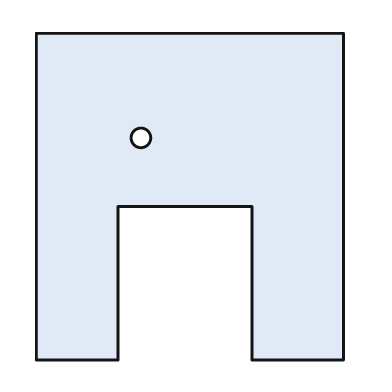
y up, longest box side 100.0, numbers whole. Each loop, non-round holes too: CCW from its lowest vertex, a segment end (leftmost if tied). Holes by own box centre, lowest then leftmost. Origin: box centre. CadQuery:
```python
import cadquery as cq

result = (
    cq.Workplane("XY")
    .moveTo(-47.0, -50.0)
    .lineTo(-22.0, -50.0)
    .lineTo(-22.0, -3.0)
    .lineTo(19.0, -3.0)
    .lineTo(19.0, -50.0)
    .lineTo(47.0, -50.0)
    .lineTo(47.0, 50.0)
    .lineTo(-47.0, 50.0)
    .close()
    .moveTo(-15.0, 18.0)
    .circle(3.0)
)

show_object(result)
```